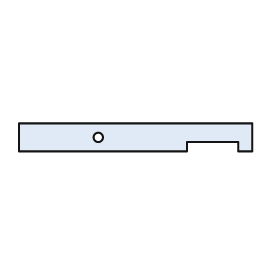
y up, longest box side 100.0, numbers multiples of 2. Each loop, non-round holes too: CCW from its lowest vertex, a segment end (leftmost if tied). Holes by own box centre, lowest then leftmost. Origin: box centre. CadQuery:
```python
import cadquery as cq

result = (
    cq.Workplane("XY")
    .moveTo(-50.0, -6.0)
    .lineTo(22.0, -6.0)
    .lineTo(22.0, -2.0)
    .lineTo(44.0, -2.0)
    .lineTo(44.0, -6.0)
    .lineTo(50.0, -6.0)
    .lineTo(50.0, 6.0)
    .lineTo(-50.0, 6.0)
    .close()
    .moveTo(-16.0, 0.0)
    .circle(2.0)
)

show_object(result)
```